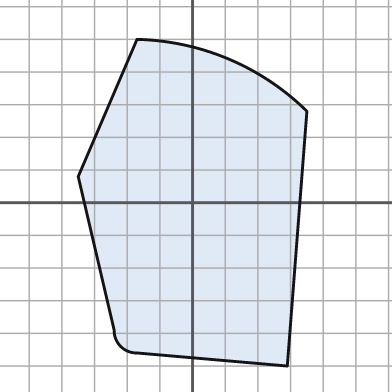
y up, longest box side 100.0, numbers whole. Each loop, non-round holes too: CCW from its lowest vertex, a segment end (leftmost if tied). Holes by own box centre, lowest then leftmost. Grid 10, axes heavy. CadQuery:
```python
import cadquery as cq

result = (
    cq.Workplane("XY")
    .moveTo(29.0, -50.0)
    .lineTo(35.0, 28.0)
    .threePointArc((11.0, 44.0), (-17.0, 50.0))
    .lineTo(-35.0, 8.0)
    .lineTo(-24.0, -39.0)
    .threePointArc((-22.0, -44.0), (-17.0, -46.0))
    .close()
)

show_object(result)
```